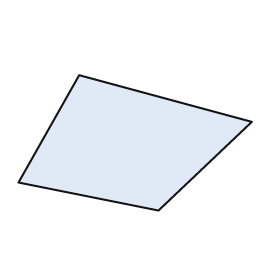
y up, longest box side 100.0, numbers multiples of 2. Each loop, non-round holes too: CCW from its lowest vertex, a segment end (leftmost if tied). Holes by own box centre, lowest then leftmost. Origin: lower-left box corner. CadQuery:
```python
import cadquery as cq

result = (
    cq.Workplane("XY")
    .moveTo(60.0, 0.0)
    .lineTo(100.0, 38.0)
    .lineTo(26.0, 58.0)
    .lineTo(0.0, 12.0)
    .close()
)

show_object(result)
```